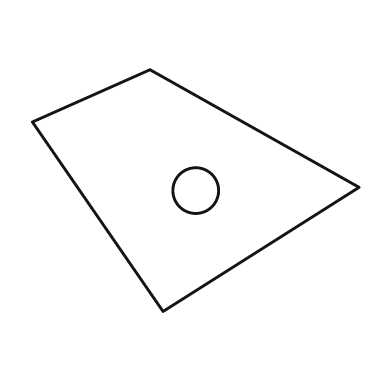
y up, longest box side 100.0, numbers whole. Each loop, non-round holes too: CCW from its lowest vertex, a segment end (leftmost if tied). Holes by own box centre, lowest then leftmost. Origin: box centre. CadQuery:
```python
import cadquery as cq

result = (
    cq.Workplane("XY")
    .moveTo(-10.0, -37.0)
    .lineTo(50.0, 1.0)
    .lineTo(-14.0, 37.0)
    .lineTo(-50.0, 21.0)
    .close()
    .moveTo(0.0, 0.0)
    .circle(7.0)
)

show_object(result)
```